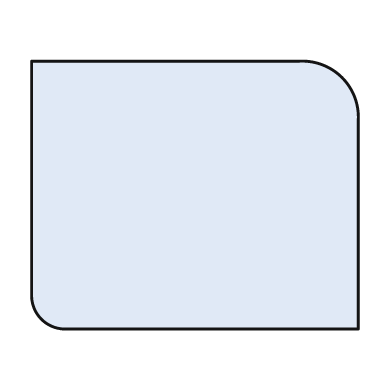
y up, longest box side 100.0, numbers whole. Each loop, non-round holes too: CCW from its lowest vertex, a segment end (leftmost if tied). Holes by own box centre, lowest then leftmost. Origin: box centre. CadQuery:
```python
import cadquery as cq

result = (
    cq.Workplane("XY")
    .moveTo(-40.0, -41.0)
    .lineTo(50.0, -41.0)
    .lineTo(50.0, 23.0)
    .threePointArc((45.0, 36.0), (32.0, 41.0))
    .lineTo(-50.0, 41.0)
    .lineTo(-50.0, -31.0)
    .threePointArc((-47.0, -38.0), (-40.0, -41.0))
    .close()
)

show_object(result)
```